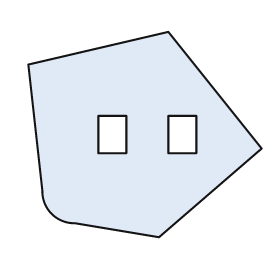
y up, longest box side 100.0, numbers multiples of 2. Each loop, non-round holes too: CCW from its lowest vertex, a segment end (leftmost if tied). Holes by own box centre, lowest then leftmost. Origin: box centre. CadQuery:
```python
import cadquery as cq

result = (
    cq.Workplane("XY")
    .moveTo(6.0, -44.0)
    .lineTo(50.0, -6.0)
    .lineTo(10.0, 44.0)
    .lineTo(-50.0, 30.0)
    .lineTo(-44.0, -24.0)
    .threePointArc((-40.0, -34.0), (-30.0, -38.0))
    .close()
    .moveTo(-20.0, -8.0)
    .lineTo(-8.0, -8.0)
    .lineTo(-8.0, 8.0)
    .lineTo(-20.0, 8.0)
    .close()
    .moveTo(10.0, -8.0)
    .lineTo(22.0, -8.0)
    .lineTo(22.0, 8.0)
    .lineTo(10.0, 8.0)
    .close()
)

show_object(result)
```